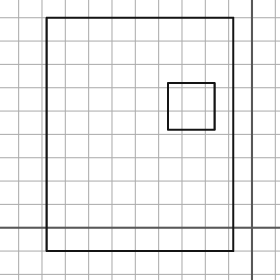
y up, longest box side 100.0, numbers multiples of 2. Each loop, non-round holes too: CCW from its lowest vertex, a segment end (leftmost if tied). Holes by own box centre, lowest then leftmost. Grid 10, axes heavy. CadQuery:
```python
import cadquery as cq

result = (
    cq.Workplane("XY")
    .moveTo(-88.0, -10.0)
    .lineTo(-8.0, -10.0)
    .lineTo(-8.0, 90.0)
    .lineTo(-88.0, 90.0)
    .close()
    .moveTo(-36.0, 42.0)
    .lineTo(-16.0, 42.0)
    .lineTo(-16.0, 62.0)
    .lineTo(-36.0, 62.0)
    .close()
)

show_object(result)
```